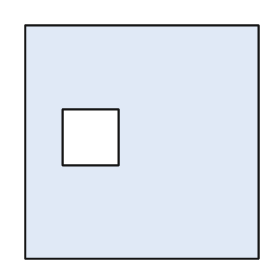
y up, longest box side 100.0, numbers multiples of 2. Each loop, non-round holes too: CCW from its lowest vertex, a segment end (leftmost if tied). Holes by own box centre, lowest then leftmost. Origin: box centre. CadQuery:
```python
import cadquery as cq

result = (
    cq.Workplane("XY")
    .moveTo(-50.0, -50.0)
    .lineTo(50.0, -50.0)
    .lineTo(50.0, 50.0)
    .lineTo(-50.0, 50.0)
    .close()
    .moveTo(-34.0, -10.0)
    .lineTo(-10.0, -10.0)
    .lineTo(-10.0, 14.0)
    .lineTo(-34.0, 14.0)
    .close()
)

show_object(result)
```